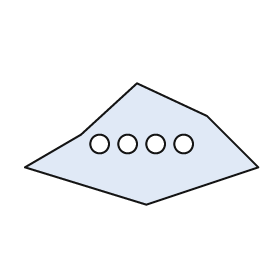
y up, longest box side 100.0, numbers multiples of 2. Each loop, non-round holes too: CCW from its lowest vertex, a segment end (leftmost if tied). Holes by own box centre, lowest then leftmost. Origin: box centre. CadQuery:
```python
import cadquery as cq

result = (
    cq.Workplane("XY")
    .moveTo(2.0, -26.0)
    .lineTo(50.0, -10.0)
    .lineTo(28.0, 12.0)
    .lineTo(-2.0, 26.0)
    .lineTo(-26.0, 4.0)
    .lineTo(-50.0, -10.0)
    .close()
    .moveTo(-18.0, 0.0)
    .circle(4.0)
    .moveTo(-6.0, 0.0)
    .circle(4.0)
    .moveTo(6.0, 0.0)
    .circle(4.0)
    .moveTo(18.0, 0.0)
    .circle(4.0)
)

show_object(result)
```